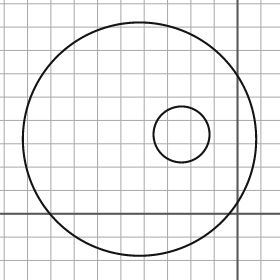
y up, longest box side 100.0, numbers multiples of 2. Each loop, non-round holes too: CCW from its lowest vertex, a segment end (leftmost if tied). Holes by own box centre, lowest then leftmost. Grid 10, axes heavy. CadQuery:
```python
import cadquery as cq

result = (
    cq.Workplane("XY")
    .moveTo(-42.0, 32.0)
    .circle(50.0)
    .moveTo(-24.0, 34.0)
    .circle(12.0)
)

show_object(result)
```